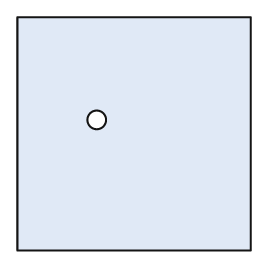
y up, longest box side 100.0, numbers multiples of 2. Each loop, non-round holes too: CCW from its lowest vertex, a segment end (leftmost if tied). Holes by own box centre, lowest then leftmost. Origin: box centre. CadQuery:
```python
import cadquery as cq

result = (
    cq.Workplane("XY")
    .moveTo(-50.0, -50.0)
    .lineTo(50.0, -50.0)
    .lineTo(50.0, 50.0)
    .lineTo(-50.0, 50.0)
    .close()
    .moveTo(-16.0, 6.0)
    .circle(4.0)
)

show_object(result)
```